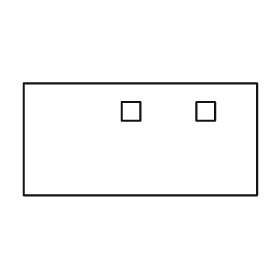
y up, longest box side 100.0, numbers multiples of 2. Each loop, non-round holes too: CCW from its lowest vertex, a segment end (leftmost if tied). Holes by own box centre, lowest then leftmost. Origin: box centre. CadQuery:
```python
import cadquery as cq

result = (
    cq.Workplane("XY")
    .moveTo(-50.0, -24.0)
    .lineTo(50.0, -24.0)
    .lineTo(50.0, 24.0)
    .lineTo(-50.0, 24.0)
    .close()
    .moveTo(-8.0, 8.0)
    .lineTo(0.0, 8.0)
    .lineTo(0.0, 16.0)
    .lineTo(-8.0, 16.0)
    .close()
    .moveTo(24.0, 8.0)
    .lineTo(32.0, 8.0)
    .lineTo(32.0, 16.0)
    .lineTo(24.0, 16.0)
    .close()
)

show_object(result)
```